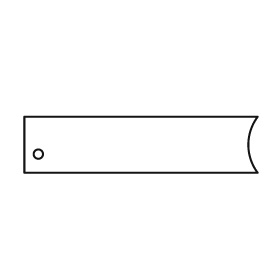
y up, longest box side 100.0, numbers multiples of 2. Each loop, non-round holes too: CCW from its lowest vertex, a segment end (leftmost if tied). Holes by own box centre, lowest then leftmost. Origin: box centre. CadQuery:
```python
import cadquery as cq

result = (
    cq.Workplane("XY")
    .moveTo(-50.0, -12.0)
    .lineTo(50.0, -12.0)
    .threePointArc((46.0, 0.0), (50.0, 12.0))
    .lineTo(-50.0, 12.0)
    .close()
    .moveTo(-44.0, -4.0)
    .circle(2.0)
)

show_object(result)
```